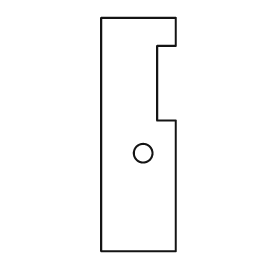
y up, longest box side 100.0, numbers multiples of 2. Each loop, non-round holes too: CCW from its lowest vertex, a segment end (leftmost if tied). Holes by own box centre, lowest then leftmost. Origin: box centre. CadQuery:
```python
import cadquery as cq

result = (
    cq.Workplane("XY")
    .moveTo(-16.0, -50.0)
    .lineTo(16.0, -50.0)
    .lineTo(16.0, 6.0)
    .lineTo(8.0, 6.0)
    .lineTo(8.0, 38.0)
    .lineTo(16.0, 38.0)
    .lineTo(16.0, 50.0)
    .lineTo(-16.0, 50.0)
    .close()
    .moveTo(2.0, -8.0)
    .circle(4.0)
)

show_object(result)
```